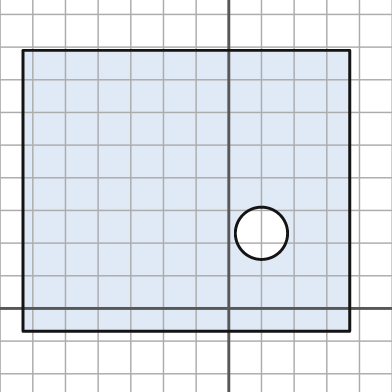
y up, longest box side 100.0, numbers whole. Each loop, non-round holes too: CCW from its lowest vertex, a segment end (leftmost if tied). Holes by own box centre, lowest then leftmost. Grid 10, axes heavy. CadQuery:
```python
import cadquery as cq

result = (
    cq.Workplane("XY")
    .moveTo(-63.0, -7.0)
    .lineTo(37.0, -7.0)
    .lineTo(37.0, 79.0)
    .lineTo(-63.0, 79.0)
    .close()
    .moveTo(10.0, 23.0)
    .circle(8.0)
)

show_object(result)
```